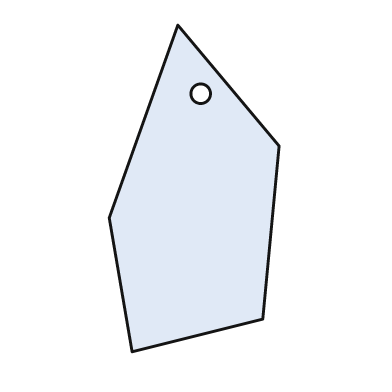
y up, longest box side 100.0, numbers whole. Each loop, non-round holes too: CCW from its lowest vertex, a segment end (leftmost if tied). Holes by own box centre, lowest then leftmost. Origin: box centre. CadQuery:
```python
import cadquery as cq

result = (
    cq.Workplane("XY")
    .moveTo(-19.0, -50.0)
    .lineTo(21.0, -40.0)
    .lineTo(26.0, 13.0)
    .lineTo(-5.0, 50.0)
    .lineTo(-26.0, -9.0)
    .close()
    .moveTo(2.0, 29.0)
    .circle(3.0)
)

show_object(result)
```